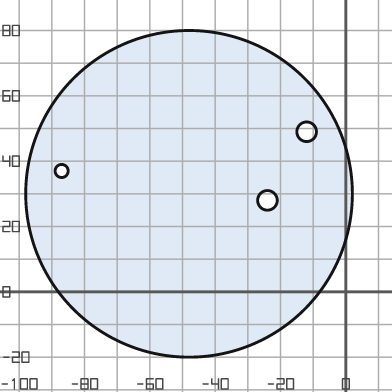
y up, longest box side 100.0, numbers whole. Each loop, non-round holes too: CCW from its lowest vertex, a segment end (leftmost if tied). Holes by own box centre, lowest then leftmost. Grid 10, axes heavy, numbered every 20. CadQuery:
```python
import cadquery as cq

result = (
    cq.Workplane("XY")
    .moveTo(-48.0, 30.0)
    .circle(50.0)
    .moveTo(-24.0, 28.0)
    .circle(3.0)
    .moveTo(-87.0, 37.0)
    .circle(2.0)
    .moveTo(-12.0, 49.0)
    .circle(3.0)
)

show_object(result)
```